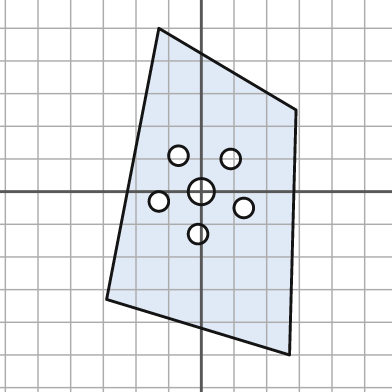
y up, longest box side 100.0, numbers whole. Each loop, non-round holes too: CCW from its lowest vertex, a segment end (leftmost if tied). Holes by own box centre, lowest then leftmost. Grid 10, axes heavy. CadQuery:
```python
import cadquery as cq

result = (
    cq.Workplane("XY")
    .moveTo(27.0, -50.0)
    .lineTo(29.0, 25.0)
    .lineTo(-13.0, 50.0)
    .lineTo(-29.0, -33.0)
    .close()
    .moveTo(-1.0, -13.0)
    .circle(3.0)
    .moveTo(13.0, -5.0)
    .circle(3.0)
    .moveTo(-13.0, -3.0)
    .circle(3.0)
    .moveTo(0.0, 0.0)
    .circle(4.0)
    .moveTo(9.0, 10.0)
    .circle(3.0)
    .moveTo(-7.0, 11.0)
    .circle(3.0)
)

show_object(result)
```